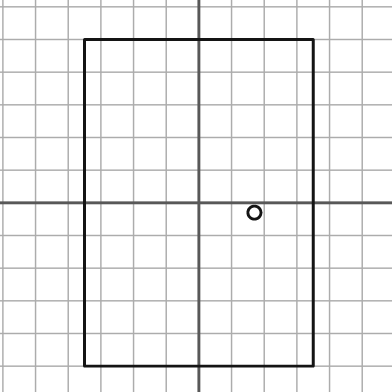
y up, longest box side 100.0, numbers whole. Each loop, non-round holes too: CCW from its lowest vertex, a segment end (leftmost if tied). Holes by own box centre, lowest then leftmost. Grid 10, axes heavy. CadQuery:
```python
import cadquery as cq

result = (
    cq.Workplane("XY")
    .moveTo(-35.0, -50.0)
    .lineTo(35.0, -50.0)
    .lineTo(35.0, 50.0)
    .lineTo(-35.0, 50.0)
    .close()
    .moveTo(17.0, -3.0)
    .circle(2.0)
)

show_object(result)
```